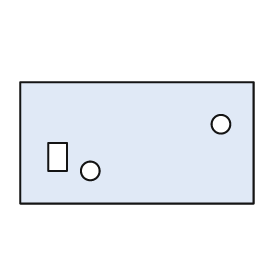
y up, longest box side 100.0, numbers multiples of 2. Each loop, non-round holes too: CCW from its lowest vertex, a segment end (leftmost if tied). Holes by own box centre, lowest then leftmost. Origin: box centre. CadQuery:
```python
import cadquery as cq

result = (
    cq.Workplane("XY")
    .moveTo(-50.0, -26.0)
    .lineTo(50.0, -26.0)
    .lineTo(50.0, 26.0)
    .lineTo(-50.0, 26.0)
    .close()
    .moveTo(-20.0, -12.0)
    .circle(4.0)
    .moveTo(-38.0, -12.0)
    .lineTo(-30.0, -12.0)
    .lineTo(-30.0, 0.0)
    .lineTo(-38.0, 0.0)
    .close()
    .moveTo(36.0, 8.0)
    .circle(4.0)
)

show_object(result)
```